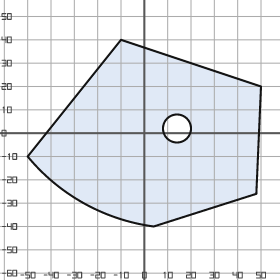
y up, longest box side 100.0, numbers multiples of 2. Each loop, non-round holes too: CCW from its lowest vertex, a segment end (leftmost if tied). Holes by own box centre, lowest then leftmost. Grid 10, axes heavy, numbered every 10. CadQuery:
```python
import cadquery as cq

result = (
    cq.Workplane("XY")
    .moveTo(4.0, -40.0)
    .lineTo(48.0, -26.0)
    .lineTo(50.0, 20.0)
    .lineTo(-10.0, 40.0)
    .lineTo(-50.0, -10.0)
    .threePointArc((-26.0, -30.0), (4.0, -40.0))
    .close()
    .moveTo(14.0, 2.0)
    .circle(6.0)
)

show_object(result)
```